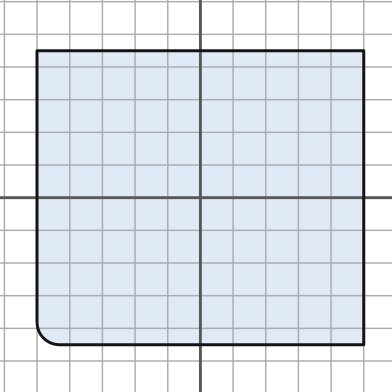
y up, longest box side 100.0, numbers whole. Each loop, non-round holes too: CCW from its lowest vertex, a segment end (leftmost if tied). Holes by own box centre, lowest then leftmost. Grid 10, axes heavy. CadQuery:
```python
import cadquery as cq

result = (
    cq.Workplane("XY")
    .moveTo(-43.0, -45.0)
    .lineTo(50.0, -45.0)
    .lineTo(50.0, 45.0)
    .lineTo(-50.0, 45.0)
    .lineTo(-50.0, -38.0)
    .threePointArc((-48.0, -43.0), (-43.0, -45.0))
    .close()
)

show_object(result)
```